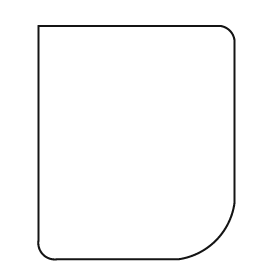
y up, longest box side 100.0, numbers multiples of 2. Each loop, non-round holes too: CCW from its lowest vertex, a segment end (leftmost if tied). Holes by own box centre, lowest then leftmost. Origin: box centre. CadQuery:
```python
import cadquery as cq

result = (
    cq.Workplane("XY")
    .moveTo(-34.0, -50.0)
    .lineTo(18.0, -50.0)
    .threePointArc((34.0, -42.0), (42.0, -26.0))
    .lineTo(42.0, 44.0)
    .threePointArc((40.0, 48.0), (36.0, 50.0))
    .lineTo(-42.0, 50.0)
    .lineTo(-42.0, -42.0)
    .threePointArc((-40.0, -48.0), (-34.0, -50.0))
    .close()
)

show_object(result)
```